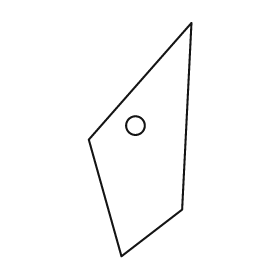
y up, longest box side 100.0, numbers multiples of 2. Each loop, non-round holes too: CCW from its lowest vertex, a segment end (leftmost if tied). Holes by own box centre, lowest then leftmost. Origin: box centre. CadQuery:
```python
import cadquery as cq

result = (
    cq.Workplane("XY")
    .moveTo(-8.0, -50.0)
    .lineTo(18.0, -30.0)
    .lineTo(22.0, 50.0)
    .lineTo(-22.0, 0.0)
    .close()
    .moveTo(-2.0, 6.0)
    .circle(4.0)
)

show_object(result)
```